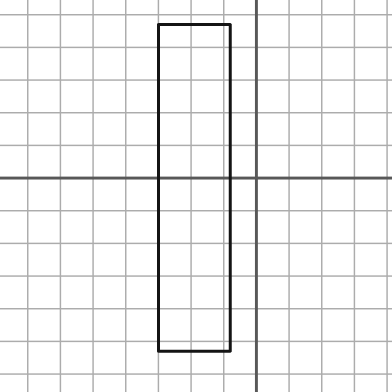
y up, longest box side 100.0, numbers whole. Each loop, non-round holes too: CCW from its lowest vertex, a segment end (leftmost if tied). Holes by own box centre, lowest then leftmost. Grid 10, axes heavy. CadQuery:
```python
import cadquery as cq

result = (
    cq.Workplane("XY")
    .moveTo(-30.0, -53.0)
    .lineTo(-8.0, -53.0)
    .lineTo(-8.0, 47.0)
    .lineTo(-30.0, 47.0)
    .close()
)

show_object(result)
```